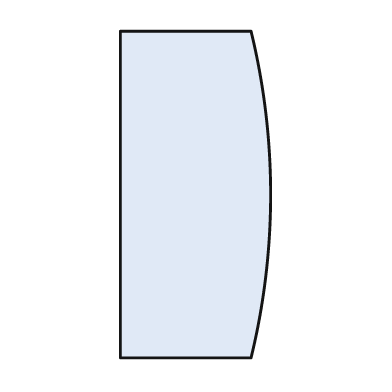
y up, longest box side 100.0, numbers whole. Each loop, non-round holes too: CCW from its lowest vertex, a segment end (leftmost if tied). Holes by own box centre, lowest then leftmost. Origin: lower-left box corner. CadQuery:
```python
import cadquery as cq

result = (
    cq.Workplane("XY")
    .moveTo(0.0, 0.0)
    .lineTo(40.0, 0.0)
    .threePointArc((46.0, 50.0), (40.0, 100.0))
    .lineTo(0.0, 100.0)
    .close()
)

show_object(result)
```